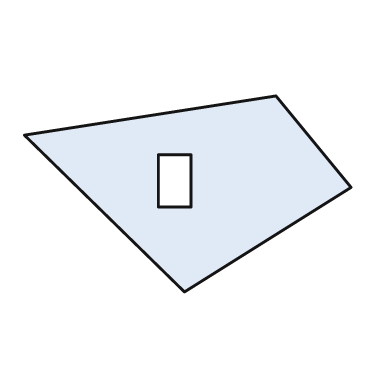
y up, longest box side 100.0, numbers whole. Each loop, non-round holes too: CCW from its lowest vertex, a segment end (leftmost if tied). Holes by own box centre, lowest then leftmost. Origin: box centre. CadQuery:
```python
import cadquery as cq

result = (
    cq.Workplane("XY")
    .moveTo(-1.0, -30.0)
    .lineTo(50.0, 2.0)
    .lineTo(27.0, 30.0)
    .lineTo(-50.0, 18.0)
    .close()
    .moveTo(-9.0, -4.0)
    .lineTo(1.0, -4.0)
    .lineTo(1.0, 12.0)
    .lineTo(-9.0, 12.0)
    .close()
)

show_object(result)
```